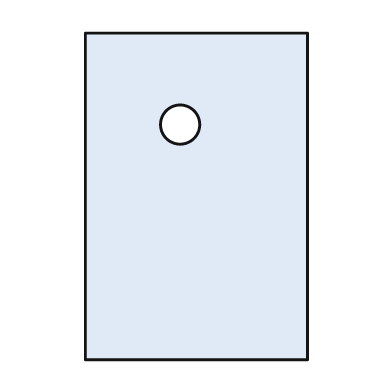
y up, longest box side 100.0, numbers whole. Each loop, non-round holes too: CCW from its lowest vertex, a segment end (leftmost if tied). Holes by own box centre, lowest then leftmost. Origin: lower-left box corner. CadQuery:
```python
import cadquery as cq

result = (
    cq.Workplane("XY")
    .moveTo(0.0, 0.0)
    .lineTo(68.0, 0.0)
    .lineTo(68.0, 100.0)
    .lineTo(0.0, 100.0)
    .close()
    .moveTo(29.0, 72.0)
    .circle(6.0)
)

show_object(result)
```